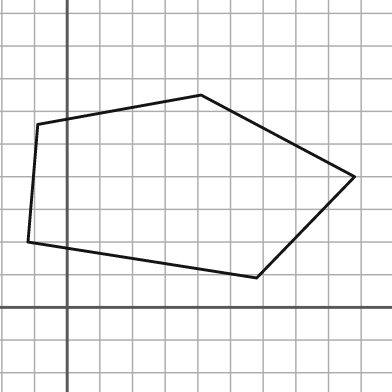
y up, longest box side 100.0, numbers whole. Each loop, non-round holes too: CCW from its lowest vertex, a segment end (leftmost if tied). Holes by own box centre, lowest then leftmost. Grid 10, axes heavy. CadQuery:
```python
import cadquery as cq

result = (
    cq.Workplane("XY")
    .moveTo(58.0, 9.0)
    .lineTo(88.0, 40.0)
    .lineTo(41.0, 65.0)
    .lineTo(-9.0, 56.0)
    .lineTo(-12.0, 20.0)
    .close()
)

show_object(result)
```